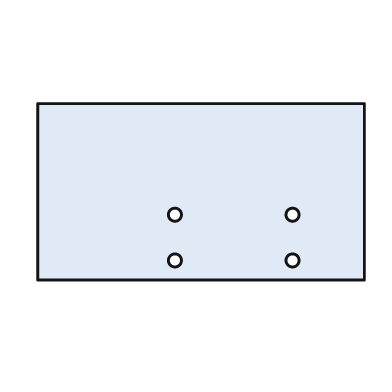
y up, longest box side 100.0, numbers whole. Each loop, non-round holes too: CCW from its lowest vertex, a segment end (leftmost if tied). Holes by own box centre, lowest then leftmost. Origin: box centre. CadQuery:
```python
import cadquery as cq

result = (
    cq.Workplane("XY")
    .moveTo(-50.0, -27.0)
    .lineTo(50.0, -27.0)
    .lineTo(50.0, 27.0)
    .lineTo(-50.0, 27.0)
    .close()
    .moveTo(-8.0, -21.0)
    .circle(2.0)
    .moveTo(28.0, -21.0)
    .circle(2.0)
    .moveTo(-8.0, -7.0)
    .circle(2.0)
    .moveTo(28.0, -7.0)
    .circle(2.0)
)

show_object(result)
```